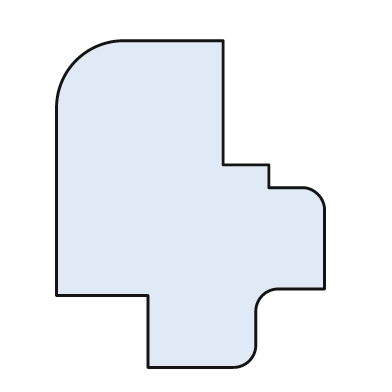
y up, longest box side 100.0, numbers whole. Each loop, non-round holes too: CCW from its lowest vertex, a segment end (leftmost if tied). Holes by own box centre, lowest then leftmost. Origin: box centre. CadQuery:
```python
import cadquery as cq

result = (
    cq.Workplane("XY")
    .moveTo(-13.0, -50.0)
    .lineTo(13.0, -50.0)
    .threePointArc((18.0, -48.0), (20.0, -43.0))
    .lineTo(20.0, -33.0)
    .threePointArc((22.0, -28.0), (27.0, -26.0))
    .lineTo(41.0, -26.0)
    .lineTo(41.0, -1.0)
    .threePointArc((39.0, 3.0), (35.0, 5.0))
    .lineTo(24.0, 5.0)
    .lineTo(24.0, 12.0)
    .lineTo(10.0, 12.0)
    .lineTo(10.0, 50.0)
    .lineTo(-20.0, 50.0)
    .threePointArc((-35.0, 44.0), (-41.0, 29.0))
    .lineTo(-41.0, -28.0)
    .lineTo(-13.0, -28.0)
    .close()
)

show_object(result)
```